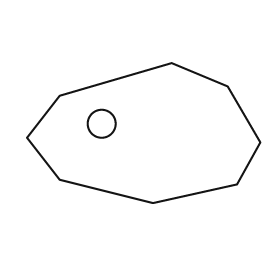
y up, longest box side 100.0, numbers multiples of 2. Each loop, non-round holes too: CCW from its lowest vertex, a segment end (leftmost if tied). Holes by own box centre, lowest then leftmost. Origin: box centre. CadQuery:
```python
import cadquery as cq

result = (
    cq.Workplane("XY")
    .moveTo(4.0, -30.0)
    .lineTo(40.0, -22.0)
    .lineTo(50.0, -4.0)
    .lineTo(36.0, 20.0)
    .lineTo(12.0, 30.0)
    .lineTo(-36.0, 16.0)
    .lineTo(-50.0, -2.0)
    .lineTo(-36.0, -20.0)
    .close()
    .moveTo(-18.0, 4.0)
    .circle(6.0)
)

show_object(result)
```